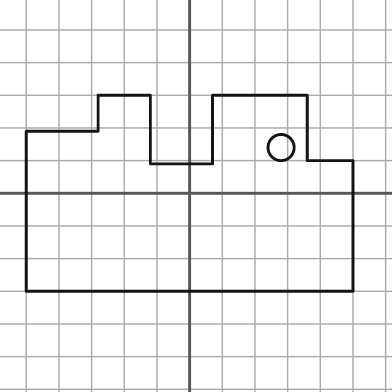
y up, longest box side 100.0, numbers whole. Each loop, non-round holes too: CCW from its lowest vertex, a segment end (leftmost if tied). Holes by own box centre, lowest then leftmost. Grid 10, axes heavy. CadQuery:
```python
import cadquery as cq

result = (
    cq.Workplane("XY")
    .moveTo(-50.0, -30.0)
    .lineTo(50.0, -30.0)
    .lineTo(50.0, 10.0)
    .lineTo(36.0, 10.0)
    .lineTo(36.0, 30.0)
    .lineTo(7.0, 30.0)
    .lineTo(7.0, 9.0)
    .lineTo(-12.0, 9.0)
    .lineTo(-12.0, 30.0)
    .lineTo(-28.0, 30.0)
    .lineTo(-28.0, 19.0)
    .lineTo(-50.0, 19.0)
    .close()
    .moveTo(28.0, 14.0)
    .circle(4.0)
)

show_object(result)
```